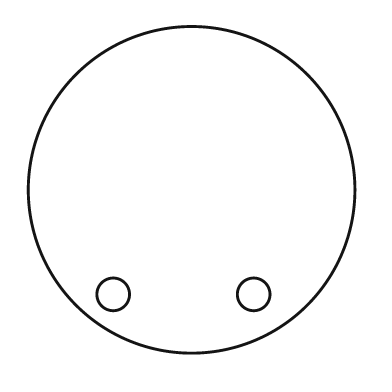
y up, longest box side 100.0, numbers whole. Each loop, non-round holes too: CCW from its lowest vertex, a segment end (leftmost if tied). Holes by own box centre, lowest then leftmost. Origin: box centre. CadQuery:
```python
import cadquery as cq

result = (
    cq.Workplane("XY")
    .moveTo(0.0, 0.0)
    .circle(50.0)
    .moveTo(-24.0, -32.0)
    .circle(5.0)
    .moveTo(19.0, -32.0)
    .circle(5.0)
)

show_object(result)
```